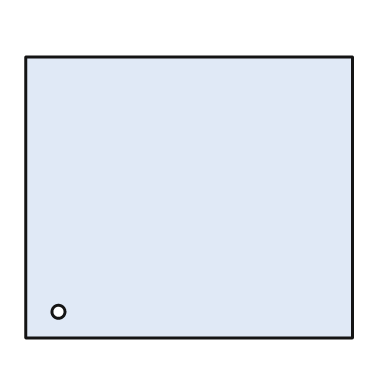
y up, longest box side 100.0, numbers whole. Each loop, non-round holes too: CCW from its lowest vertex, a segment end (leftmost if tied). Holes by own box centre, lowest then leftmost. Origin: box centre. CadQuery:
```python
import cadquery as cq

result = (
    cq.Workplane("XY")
    .moveTo(-50.0, -43.0)
    .lineTo(50.0, -43.0)
    .lineTo(50.0, 43.0)
    .lineTo(-50.0, 43.0)
    .close()
    .moveTo(-40.0, -35.0)
    .circle(2.0)
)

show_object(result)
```